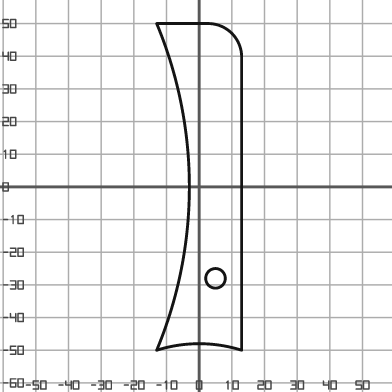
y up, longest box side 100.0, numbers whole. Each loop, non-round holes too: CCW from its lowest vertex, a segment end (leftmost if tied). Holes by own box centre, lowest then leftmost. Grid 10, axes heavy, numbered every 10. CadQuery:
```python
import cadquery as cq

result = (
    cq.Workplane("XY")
    .moveTo(-13.0, -50.0)
    .threePointArc((0.0, -48.0), (13.0, -50.0))
    .lineTo(13.0, 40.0)
    .threePointArc((10.0, 47.0), (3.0, 50.0))
    .lineTo(-13.0, 50.0)
    .threePointArc((-3.0, 0.0), (-13.0, -50.0))
    .close()
    .moveTo(5.0, -28.0)
    .circle(3.0)
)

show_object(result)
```